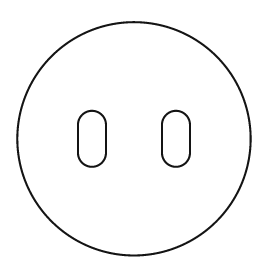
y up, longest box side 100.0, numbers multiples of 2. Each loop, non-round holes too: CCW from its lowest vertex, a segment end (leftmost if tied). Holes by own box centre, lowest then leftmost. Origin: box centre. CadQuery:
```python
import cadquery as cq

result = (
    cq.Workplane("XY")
    .moveTo(0.0, 0.0)
    .circle(50.0)
    .moveTo(-24.0, -6.0)
    .threePointArc((-18.0, -12.0), (-12.0, -6.0))
    .lineTo(-12.0, 6.0)
    .threePointArc((-18.0, 12.0), (-24.0, 6.0))
    .close()
    .moveTo(12.0, -6.0)
    .threePointArc((18.0, -12.0), (24.0, -6.0))
    .lineTo(24.0, 6.0)
    .threePointArc((18.0, 12.0), (12.0, 6.0))
    .close()
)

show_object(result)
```